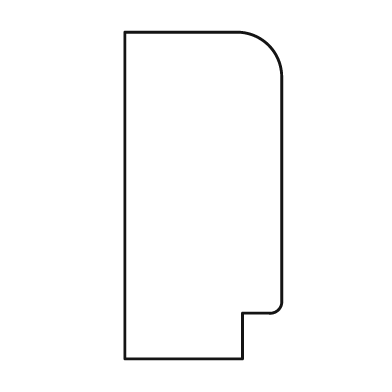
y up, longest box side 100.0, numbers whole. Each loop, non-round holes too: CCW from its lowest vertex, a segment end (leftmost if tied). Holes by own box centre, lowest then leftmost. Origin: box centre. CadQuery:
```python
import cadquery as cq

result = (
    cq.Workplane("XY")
    .moveTo(-24.0, -50.0)
    .lineTo(12.0, -50.0)
    .lineTo(12.0, -36.0)
    .lineTo(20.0, -36.0)
    .threePointArc((23.0, -35.0), (24.0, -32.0))
    .lineTo(24.0, 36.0)
    .threePointArc((20.0, 46.0), (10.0, 50.0))
    .lineTo(-24.0, 50.0)
    .close()
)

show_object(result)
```